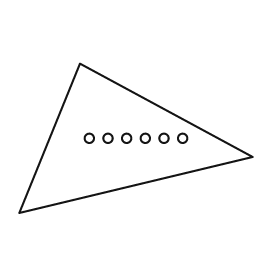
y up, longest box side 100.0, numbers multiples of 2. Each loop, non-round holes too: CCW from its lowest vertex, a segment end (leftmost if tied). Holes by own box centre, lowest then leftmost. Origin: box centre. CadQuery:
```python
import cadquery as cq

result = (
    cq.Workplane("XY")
    .moveTo(-50.0, -32.0)
    .lineTo(50.0, -8.0)
    .lineTo(-24.0, 32.0)
    .close()
    .moveTo(-20.0, 0.0)
    .circle(2.0)
    .moveTo(-12.0, 0.0)
    .circle(2.0)
    .moveTo(-4.0, 0.0)
    .circle(2.0)
    .moveTo(4.0, 0.0)
    .circle(2.0)
    .moveTo(12.0, 0.0)
    .circle(2.0)
    .moveTo(20.0, 0.0)
    .circle(2.0)
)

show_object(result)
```